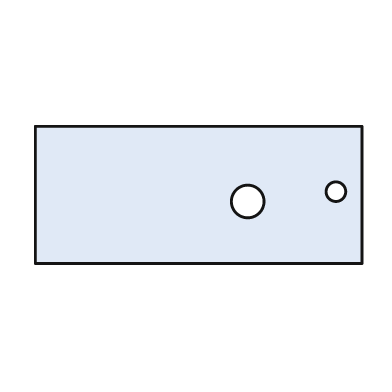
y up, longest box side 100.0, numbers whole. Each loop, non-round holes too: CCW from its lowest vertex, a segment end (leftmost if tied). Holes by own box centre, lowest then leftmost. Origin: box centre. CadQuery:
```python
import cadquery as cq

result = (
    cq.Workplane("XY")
    .moveTo(-50.0, -21.0)
    .lineTo(50.0, -21.0)
    .lineTo(50.0, 21.0)
    .lineTo(-50.0, 21.0)
    .close()
    .moveTo(15.0, -2.0)
    .circle(5.0)
    .moveTo(42.0, 1.0)
    .circle(3.0)
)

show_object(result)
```